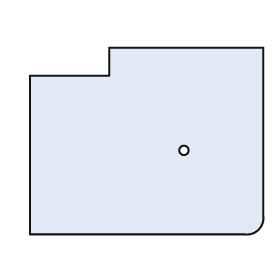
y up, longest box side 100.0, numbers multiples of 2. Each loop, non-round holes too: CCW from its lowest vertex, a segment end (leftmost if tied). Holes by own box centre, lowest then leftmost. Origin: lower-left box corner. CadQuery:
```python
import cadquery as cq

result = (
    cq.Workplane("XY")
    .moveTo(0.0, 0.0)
    .lineTo(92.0, 0.0)
    .threePointArc((98.0, 2.0), (100.0, 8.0))
    .lineTo(100.0, 80.0)
    .lineTo(34.0, 80.0)
    .lineTo(34.0, 68.0)
    .lineTo(0.0, 68.0)
    .close()
    .moveTo(66.0, 36.0)
    .circle(2.0)
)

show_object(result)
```